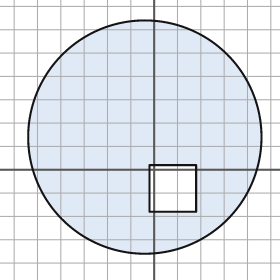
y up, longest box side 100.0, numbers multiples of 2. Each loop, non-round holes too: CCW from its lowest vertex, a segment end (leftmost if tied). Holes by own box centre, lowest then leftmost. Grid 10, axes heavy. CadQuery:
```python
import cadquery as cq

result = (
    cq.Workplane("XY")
    .moveTo(-4.0, 14.0)
    .circle(50.0)
    .moveTo(-2.0, -18.0)
    .lineTo(18.0, -18.0)
    .lineTo(18.0, 2.0)
    .lineTo(-2.0, 2.0)
    .close()
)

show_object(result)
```